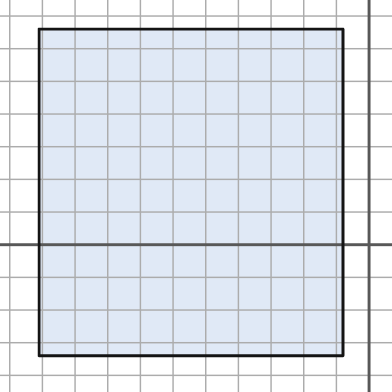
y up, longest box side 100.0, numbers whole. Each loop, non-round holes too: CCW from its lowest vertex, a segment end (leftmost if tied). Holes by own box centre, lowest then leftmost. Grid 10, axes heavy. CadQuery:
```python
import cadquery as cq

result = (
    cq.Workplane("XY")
    .moveTo(-101.0, -34.0)
    .lineTo(-8.0, -34.0)
    .lineTo(-8.0, 66.0)
    .lineTo(-101.0, 66.0)
    .close()
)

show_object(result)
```